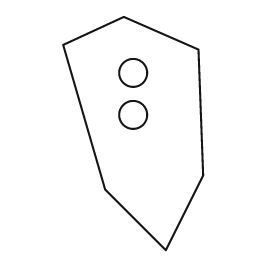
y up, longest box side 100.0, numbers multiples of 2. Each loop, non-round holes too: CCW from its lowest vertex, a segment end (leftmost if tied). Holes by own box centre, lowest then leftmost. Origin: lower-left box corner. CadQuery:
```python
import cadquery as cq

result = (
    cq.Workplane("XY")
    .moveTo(44.0, 0.0)
    .lineTo(60.0, 32.0)
    .lineTo(58.0, 86.0)
    .lineTo(26.0, 100.0)
    .lineTo(0.0, 88.0)
    .lineTo(18.0, 26.0)
    .close()
    .moveTo(30.0, 58.0)
    .circle(6.0)
    .moveTo(30.0, 76.0)
    .circle(6.0)
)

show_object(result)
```